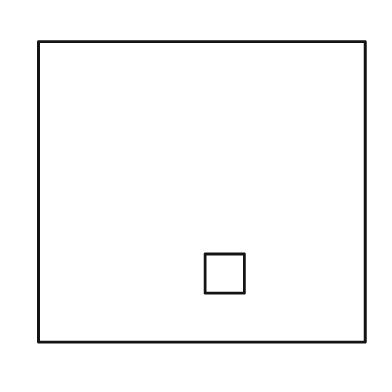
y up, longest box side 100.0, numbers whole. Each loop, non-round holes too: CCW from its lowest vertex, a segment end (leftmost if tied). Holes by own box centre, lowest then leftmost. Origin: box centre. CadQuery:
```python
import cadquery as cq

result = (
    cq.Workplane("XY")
    .moveTo(-50.0, -46.0)
    .lineTo(50.0, -46.0)
    .lineTo(50.0, 46.0)
    .lineTo(-50.0, 46.0)
    .close()
    .moveTo(1.0, -31.0)
    .lineTo(13.0, -31.0)
    .lineTo(13.0, -19.0)
    .lineTo(1.0, -19.0)
    .close()
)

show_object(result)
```